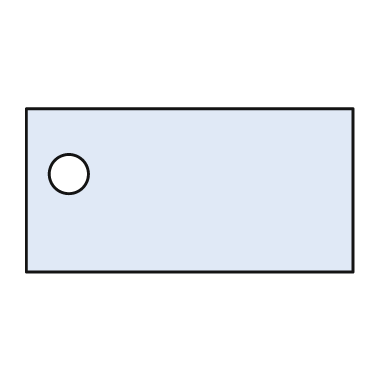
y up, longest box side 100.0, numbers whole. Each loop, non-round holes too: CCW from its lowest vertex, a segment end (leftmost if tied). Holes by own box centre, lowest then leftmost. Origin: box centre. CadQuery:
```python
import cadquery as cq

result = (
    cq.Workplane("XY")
    .moveTo(-50.0, -25.0)
    .lineTo(50.0, -25.0)
    .lineTo(50.0, 25.0)
    .lineTo(-50.0, 25.0)
    .close()
    .moveTo(-37.0, 5.0)
    .circle(6.0)
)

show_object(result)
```